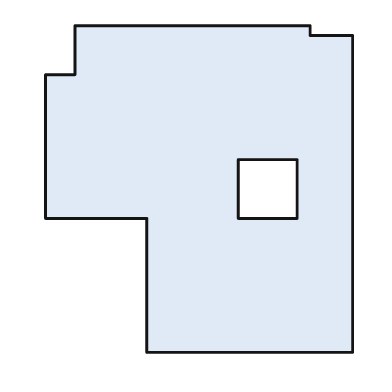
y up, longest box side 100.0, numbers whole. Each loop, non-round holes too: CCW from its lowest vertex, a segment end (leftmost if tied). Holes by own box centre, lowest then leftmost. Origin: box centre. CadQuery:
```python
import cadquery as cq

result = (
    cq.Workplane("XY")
    .moveTo(-16.0, -50.0)
    .lineTo(47.0, -50.0)
    .lineTo(47.0, 47.0)
    .lineTo(34.0, 47.0)
    .lineTo(34.0, 50.0)
    .lineTo(-38.0, 50.0)
    .lineTo(-38.0, 35.0)
    .lineTo(-47.0, 35.0)
    .lineTo(-47.0, -9.0)
    .lineTo(-16.0, -9.0)
    .close()
    .moveTo(12.0, -9.0)
    .lineTo(30.0, -9.0)
    .lineTo(30.0, 9.0)
    .lineTo(12.0, 9.0)
    .close()
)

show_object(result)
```